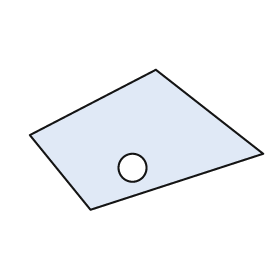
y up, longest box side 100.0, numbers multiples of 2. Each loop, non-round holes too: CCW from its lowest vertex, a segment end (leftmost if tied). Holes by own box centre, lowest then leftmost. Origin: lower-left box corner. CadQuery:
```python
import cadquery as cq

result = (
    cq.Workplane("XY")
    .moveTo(26.0, 0.0)
    .lineTo(100.0, 24.0)
    .lineTo(54.0, 60.0)
    .lineTo(0.0, 32.0)
    .close()
    .moveTo(44.0, 18.0)
    .circle(6.0)
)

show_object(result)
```